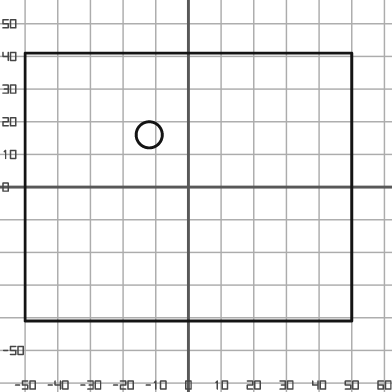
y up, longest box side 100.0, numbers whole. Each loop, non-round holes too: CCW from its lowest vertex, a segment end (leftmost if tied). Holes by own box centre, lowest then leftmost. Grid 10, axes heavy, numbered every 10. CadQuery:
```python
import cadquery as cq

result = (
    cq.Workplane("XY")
    .moveTo(-50.0, -41.0)
    .lineTo(50.0, -41.0)
    .lineTo(50.0, 41.0)
    .lineTo(-50.0, 41.0)
    .close()
    .moveTo(-12.0, 16.0)
    .circle(4.0)
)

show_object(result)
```